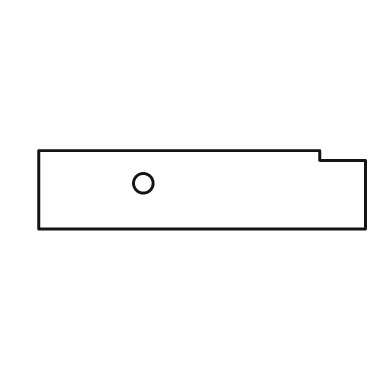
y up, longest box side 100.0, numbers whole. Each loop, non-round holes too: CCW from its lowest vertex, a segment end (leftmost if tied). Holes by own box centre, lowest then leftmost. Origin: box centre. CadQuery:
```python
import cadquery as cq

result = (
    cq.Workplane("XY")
    .moveTo(-50.0, -12.0)
    .lineTo(50.0, -12.0)
    .lineTo(50.0, 9.0)
    .lineTo(36.0, 9.0)
    .lineTo(36.0, 12.0)
    .lineTo(-50.0, 12.0)
    .close()
    .moveTo(-18.0, 2.0)
    .circle(3.0)
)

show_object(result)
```